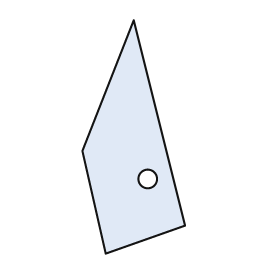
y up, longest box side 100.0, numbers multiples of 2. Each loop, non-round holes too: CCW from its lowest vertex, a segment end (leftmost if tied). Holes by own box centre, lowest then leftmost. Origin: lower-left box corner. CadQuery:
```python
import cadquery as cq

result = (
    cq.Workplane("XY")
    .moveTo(10.0, 0.0)
    .lineTo(44.0, 12.0)
    .lineTo(22.0, 100.0)
    .lineTo(0.0, 44.0)
    .close()
    .moveTo(28.0, 32.0)
    .circle(4.0)
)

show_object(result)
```